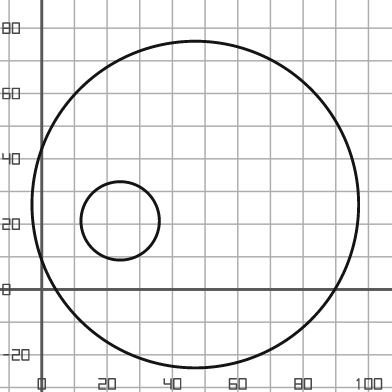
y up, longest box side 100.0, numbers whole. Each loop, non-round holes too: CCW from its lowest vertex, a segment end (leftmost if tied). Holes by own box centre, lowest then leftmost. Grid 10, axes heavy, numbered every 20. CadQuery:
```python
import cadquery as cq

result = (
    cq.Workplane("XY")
    .moveTo(47.0, 26.0)
    .circle(50.0)
    .moveTo(24.0, 21.0)
    .circle(12.0)
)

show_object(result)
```